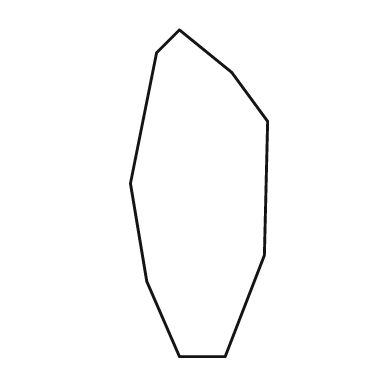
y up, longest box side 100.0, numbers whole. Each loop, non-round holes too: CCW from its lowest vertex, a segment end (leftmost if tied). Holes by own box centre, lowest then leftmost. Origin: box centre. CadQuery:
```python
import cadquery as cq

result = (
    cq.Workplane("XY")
    .moveTo(-6.0, -50.0)
    .lineTo(8.0, -50.0)
    .lineTo(20.0, -19.0)
    .lineTo(21.0, 22.0)
    .lineTo(10.0, 37.0)
    .lineTo(-6.0, 50.0)
    .lineTo(-13.0, 43.0)
    .lineTo(-21.0, 3.0)
    .lineTo(-16.0, -27.0)
    .close()
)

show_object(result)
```